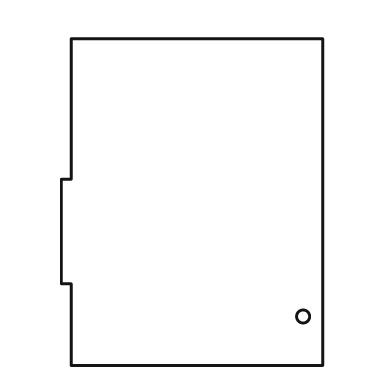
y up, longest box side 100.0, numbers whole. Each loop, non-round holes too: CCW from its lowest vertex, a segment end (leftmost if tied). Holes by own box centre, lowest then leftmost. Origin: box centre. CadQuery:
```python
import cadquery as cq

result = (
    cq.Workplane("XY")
    .moveTo(-37.0, -50.0)
    .lineTo(40.0, -50.0)
    .lineTo(40.0, 50.0)
    .lineTo(-37.0, 50.0)
    .lineTo(-37.0, 7.0)
    .lineTo(-40.0, 7.0)
    .lineTo(-40.0, -25.0)
    .lineTo(-37.0, -25.0)
    .close()
    .moveTo(34.0, -35.0)
    .circle(2.0)
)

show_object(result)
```